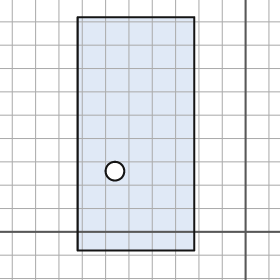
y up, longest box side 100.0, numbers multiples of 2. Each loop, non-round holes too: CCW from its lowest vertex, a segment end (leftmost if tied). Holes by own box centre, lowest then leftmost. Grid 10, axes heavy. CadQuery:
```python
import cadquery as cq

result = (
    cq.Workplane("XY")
    .moveTo(-72.0, -8.0)
    .lineTo(-22.0, -8.0)
    .lineTo(-22.0, 92.0)
    .lineTo(-72.0, 92.0)
    .close()
    .moveTo(-56.0, 26.0)
    .circle(4.0)
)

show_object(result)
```